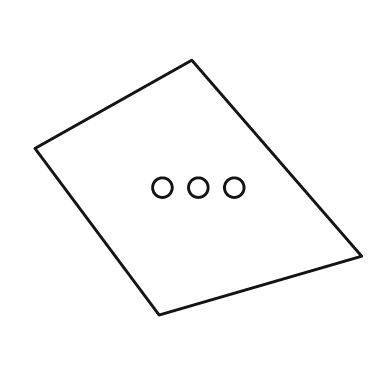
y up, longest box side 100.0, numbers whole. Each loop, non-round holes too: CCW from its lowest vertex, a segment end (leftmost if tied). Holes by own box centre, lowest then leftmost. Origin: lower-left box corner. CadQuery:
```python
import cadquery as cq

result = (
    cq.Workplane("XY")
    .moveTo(38.0, 0.0)
    .lineTo(100.0, 18.0)
    .lineTo(48.0, 78.0)
    .lineTo(0.0, 51.0)
    .close()
    .moveTo(39.0, 39.0)
    .circle(3.0)
    .moveTo(50.0, 39.0)
    .circle(3.0)
    .moveTo(61.0, 39.0)
    .circle(3.0)
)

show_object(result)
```